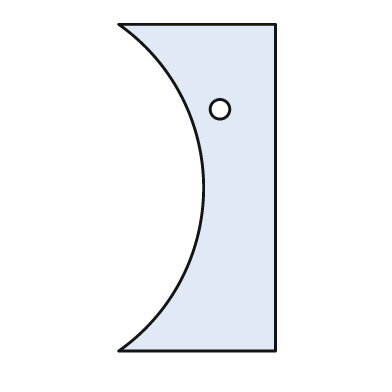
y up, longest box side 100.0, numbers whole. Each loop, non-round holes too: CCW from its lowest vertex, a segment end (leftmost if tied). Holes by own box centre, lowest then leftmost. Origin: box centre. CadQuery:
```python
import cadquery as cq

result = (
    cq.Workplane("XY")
    .moveTo(-24.0, -50.0)
    .lineTo(24.0, -50.0)
    .lineTo(24.0, 50.0)
    .lineTo(-24.0, 50.0)
    .threePointArc((2.0, 0.0), (-24.0, -50.0))
    .close()
    .moveTo(7.0, 24.0)
    .circle(3.0)
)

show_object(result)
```